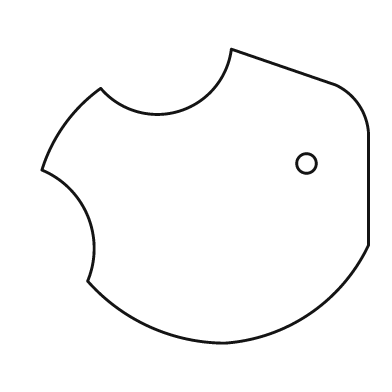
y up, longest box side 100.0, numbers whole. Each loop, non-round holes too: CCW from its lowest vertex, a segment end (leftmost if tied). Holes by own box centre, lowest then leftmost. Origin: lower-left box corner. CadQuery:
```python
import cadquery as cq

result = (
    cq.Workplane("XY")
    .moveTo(56.0, 0.0)
    .threePointArc((82.0, 9.0), (100.0, 30.0))
    .lineTo(100.0, 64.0)
    .threePointArc((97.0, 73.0), (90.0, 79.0))
    .lineTo(58.0, 90.0)
    .threePointArc((42.0, 71.0), (18.0, 78.0))
    .threePointArc((7.0, 67.0), (0.0, 53.0))
    .threePointArc((14.0, 39.0), (14.0, 19.0))
    .threePointArc((33.0, 5.0), (56.0, 0.0))
    .close()
    .moveTo(81.0, 55.0)
    .circle(3.0)
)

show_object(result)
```